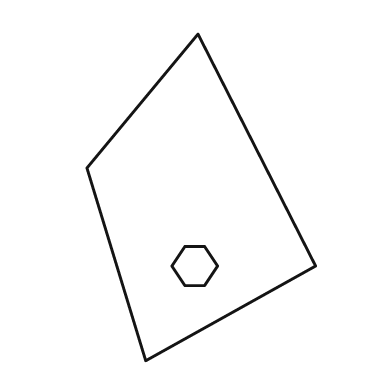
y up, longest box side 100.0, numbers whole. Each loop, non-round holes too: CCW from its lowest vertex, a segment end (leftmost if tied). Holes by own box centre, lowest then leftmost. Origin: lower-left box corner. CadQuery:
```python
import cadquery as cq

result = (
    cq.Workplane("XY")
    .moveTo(18.0, 0.0)
    .lineTo(70.0, 29.0)
    .lineTo(34.0, 100.0)
    .lineTo(0.0, 59.0)
    .close()
    .moveTo(30.0, 23.0)
    .lineTo(36.0, 23.0)
    .lineTo(40.0, 29.0)
    .lineTo(36.0, 35.0)
    .lineTo(30.0, 35.0)
    .lineTo(26.0, 29.0)
    .close()
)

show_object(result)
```